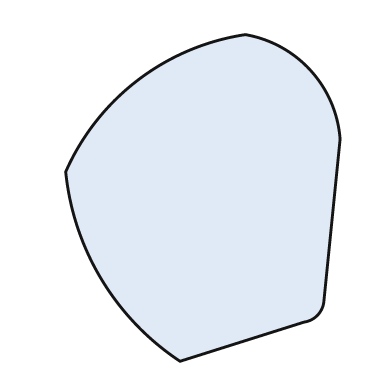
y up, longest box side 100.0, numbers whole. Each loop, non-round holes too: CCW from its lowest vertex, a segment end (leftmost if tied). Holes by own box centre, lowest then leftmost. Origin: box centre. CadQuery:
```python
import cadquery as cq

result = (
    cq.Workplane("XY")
    .moveTo(-7.0, -50.0)
    .lineTo(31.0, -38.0)
    .threePointArc((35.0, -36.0), (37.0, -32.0))
    .lineTo(42.0, 18.0)
    .threePointArc((33.0, 39.0), (13.0, 50.0))
    .threePointArc((-20.0, 36.0), (-42.0, 8.0))
    .threePointArc((-31.0, -25.0), (-7.0, -50.0))
    .close()
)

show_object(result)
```